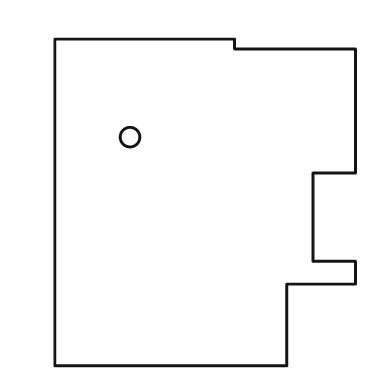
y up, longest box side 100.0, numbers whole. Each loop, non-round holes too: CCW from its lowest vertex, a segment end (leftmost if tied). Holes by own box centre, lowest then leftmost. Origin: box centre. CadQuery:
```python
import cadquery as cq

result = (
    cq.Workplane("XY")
    .moveTo(-46.0, -50.0)
    .lineTo(25.0, -50.0)
    .lineTo(25.0, -25.0)
    .lineTo(46.0, -25.0)
    .lineTo(46.0, -18.0)
    .lineTo(33.0, -18.0)
    .lineTo(33.0, 9.0)
    .lineTo(46.0, 9.0)
    .lineTo(46.0, 47.0)
    .lineTo(9.0, 47.0)
    .lineTo(9.0, 50.0)
    .lineTo(-46.0, 50.0)
    .close()
    .moveTo(-23.0, 20.0)
    .circle(3.0)
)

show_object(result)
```